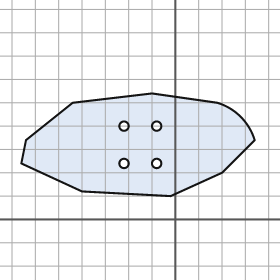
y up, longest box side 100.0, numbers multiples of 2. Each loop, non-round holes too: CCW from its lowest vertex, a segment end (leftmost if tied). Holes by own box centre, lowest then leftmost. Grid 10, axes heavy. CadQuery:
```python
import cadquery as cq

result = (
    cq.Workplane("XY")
    .moveTo(-2.0, 10.0)
    .lineTo(20.0, 20.0)
    .lineTo(34.0, 34.0)
    .threePointArc((28.0, 44.0), (18.0, 50.0))
    .lineTo(-10.0, 54.0)
    .lineTo(-44.0, 50.0)
    .lineTo(-64.0, 34.0)
    .lineTo(-66.0, 24.0)
    .lineTo(-40.0, 12.0)
    .close()
    .moveTo(-22.0, 24.0)
    .circle(2.0)
    .moveTo(-8.0, 24.0)
    .circle(2.0)
    .moveTo(-22.0, 40.0)
    .circle(2.0)
    .moveTo(-8.0, 40.0)
    .circle(2.0)
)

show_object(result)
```